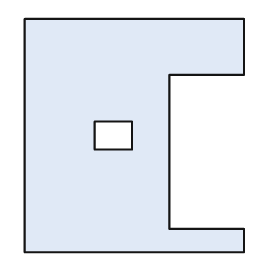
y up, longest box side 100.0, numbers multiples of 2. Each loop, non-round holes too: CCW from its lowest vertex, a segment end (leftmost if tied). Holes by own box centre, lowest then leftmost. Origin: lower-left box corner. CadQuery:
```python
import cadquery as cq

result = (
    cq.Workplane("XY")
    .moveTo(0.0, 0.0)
    .lineTo(94.0, 0.0)
    .lineTo(94.0, 10.0)
    .lineTo(62.0, 10.0)
    .lineTo(62.0, 76.0)
    .lineTo(94.0, 76.0)
    .lineTo(94.0, 100.0)
    .lineTo(0.0, 100.0)
    .close()
    .moveTo(30.0, 44.0)
    .lineTo(46.0, 44.0)
    .lineTo(46.0, 56.0)
    .lineTo(30.0, 56.0)
    .close()
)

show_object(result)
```